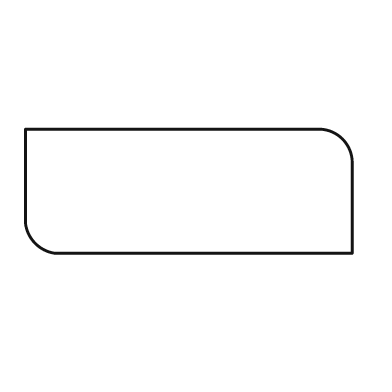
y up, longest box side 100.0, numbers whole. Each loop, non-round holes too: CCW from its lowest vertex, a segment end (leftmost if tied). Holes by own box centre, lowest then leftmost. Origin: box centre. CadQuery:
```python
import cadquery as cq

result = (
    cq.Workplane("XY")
    .moveTo(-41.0, -19.0)
    .lineTo(50.0, -19.0)
    .lineTo(50.0, 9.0)
    .threePointArc((47.0, 16.0), (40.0, 19.0))
    .lineTo(-50.0, 19.0)
    .lineTo(-50.0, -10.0)
    .threePointArc((-47.0, -16.0), (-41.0, -19.0))
    .close()
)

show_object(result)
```